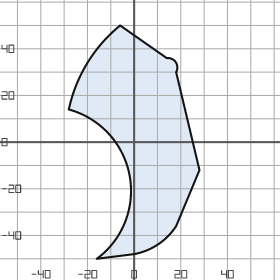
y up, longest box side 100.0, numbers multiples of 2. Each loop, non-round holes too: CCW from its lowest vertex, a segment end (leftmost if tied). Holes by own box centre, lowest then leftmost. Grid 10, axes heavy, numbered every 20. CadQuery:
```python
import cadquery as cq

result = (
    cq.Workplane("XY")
    .moveTo(-16.0, -50.0)
    .lineTo(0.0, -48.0)
    .threePointArc((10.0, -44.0), (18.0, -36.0))
    .lineTo(28.0, -12.0)
    .lineTo(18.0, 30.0)
    .threePointArc((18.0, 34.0), (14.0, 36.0))
    .lineTo(-6.0, 50.0)
    .threePointArc((-20.0, 34.0), (-28.0, 14.0))
    .threePointArc((-2.0, -14.0), (-16.0, -50.0))
    .close()
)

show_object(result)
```